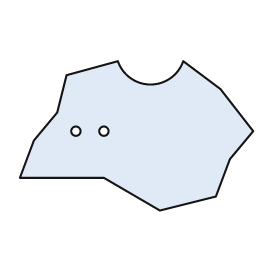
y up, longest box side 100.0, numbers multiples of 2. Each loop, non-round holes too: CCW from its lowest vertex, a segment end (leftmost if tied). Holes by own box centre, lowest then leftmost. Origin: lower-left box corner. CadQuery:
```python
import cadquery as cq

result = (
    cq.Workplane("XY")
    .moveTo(60.0, 0.0)
    .lineTo(84.0, 6.0)
    .lineTo(90.0, 22.0)
    .lineTo(100.0, 34.0)
    .lineTo(86.0, 52.0)
    .lineTo(70.0, 64.0)
    .threePointArc((56.0, 54.0), (42.0, 64.0))
    .lineTo(20.0, 58.0)
    .lineTo(16.0, 42.0)
    .lineTo(6.0, 30.0)
    .lineTo(0.0, 14.0)
    .lineTo(36.0, 14.0)
    .close()
    .moveTo(24.0, 34.0)
    .circle(2.0)
    .moveTo(36.0, 34.0)
    .circle(2.0)
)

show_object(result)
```